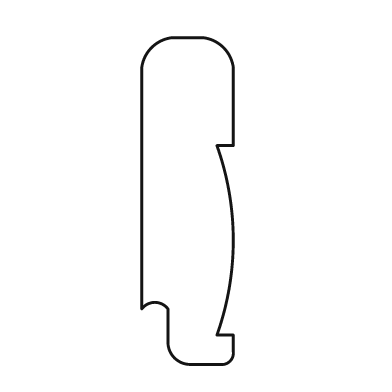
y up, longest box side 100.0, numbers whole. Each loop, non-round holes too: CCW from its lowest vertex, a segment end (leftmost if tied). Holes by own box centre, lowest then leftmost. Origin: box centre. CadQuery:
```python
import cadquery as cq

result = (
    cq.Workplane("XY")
    .moveTo(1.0, -50.0)
    .lineTo(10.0, -50.0)
    .threePointArc((13.0, -49.0), (14.0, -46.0))
    .lineTo(14.0, -41.0)
    .lineTo(9.0, -41.0)
    .threePointArc((14.0, -12.0), (9.0, 17.0))
    .lineTo(14.0, 17.0)
    .lineTo(14.0, 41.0)
    .threePointArc((11.0, 47.0), (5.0, 50.0))
    .lineTo(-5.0, 50.0)
    .threePointArc((-11.0, 47.0), (-14.0, 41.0))
    .lineTo(-14.0, -33.0)
    .threePointArc((-10.0, -31.0), (-6.0, -33.0))
    .lineTo(-6.0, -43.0)
    .threePointArc((-4.0, -48.0), (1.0, -50.0))
    .close()
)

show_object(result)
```